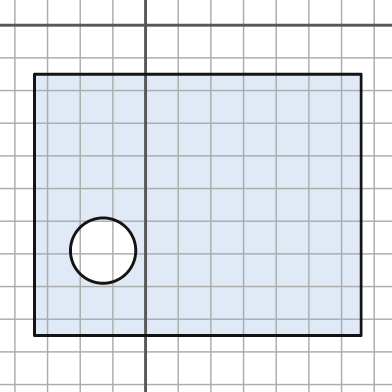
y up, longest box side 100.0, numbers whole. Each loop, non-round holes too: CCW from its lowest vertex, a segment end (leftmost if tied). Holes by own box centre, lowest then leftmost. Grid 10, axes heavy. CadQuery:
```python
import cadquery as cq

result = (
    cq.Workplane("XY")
    .moveTo(-34.0, -95.0)
    .lineTo(66.0, -95.0)
    .lineTo(66.0, -15.0)
    .lineTo(-34.0, -15.0)
    .close()
    .moveTo(-13.0, -69.0)
    .circle(10.0)
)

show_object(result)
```